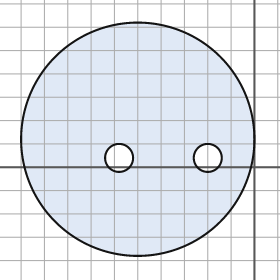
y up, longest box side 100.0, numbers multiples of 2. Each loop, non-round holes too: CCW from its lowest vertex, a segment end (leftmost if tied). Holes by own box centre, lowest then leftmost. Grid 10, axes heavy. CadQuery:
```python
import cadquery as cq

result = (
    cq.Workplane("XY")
    .moveTo(-50.0, 12.0)
    .circle(50.0)
    .moveTo(-58.0, 4.0)
    .circle(6.0)
    .moveTo(-20.0, 4.0)
    .circle(6.0)
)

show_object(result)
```